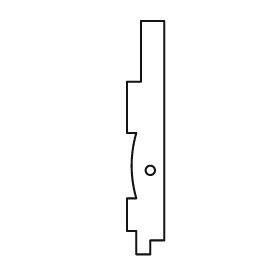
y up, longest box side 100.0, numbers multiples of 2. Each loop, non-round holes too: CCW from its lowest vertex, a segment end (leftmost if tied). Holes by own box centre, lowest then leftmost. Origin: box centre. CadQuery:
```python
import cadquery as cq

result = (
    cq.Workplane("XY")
    .moveTo(-4.0, -50.0)
    .lineTo(2.0, -50.0)
    .lineTo(2.0, -44.0)
    .lineTo(8.0, -44.0)
    .lineTo(8.0, 50.0)
    .lineTo(-2.0, 50.0)
    .lineTo(-2.0, 24.0)
    .lineTo(-8.0, 24.0)
    .lineTo(-8.0, 2.0)
    .lineTo(-4.0, 2.0)
    .threePointArc((-6.0, -12.0), (-4.0, -26.0))
    .lineTo(-8.0, -26.0)
    .lineTo(-8.0, -40.0)
    .lineTo(-4.0, -40.0)
    .close()
    .moveTo(2.0, -14.0)
    .circle(2.0)
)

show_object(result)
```